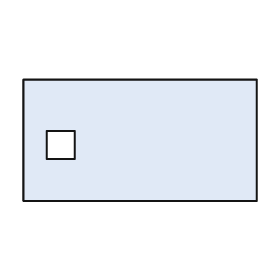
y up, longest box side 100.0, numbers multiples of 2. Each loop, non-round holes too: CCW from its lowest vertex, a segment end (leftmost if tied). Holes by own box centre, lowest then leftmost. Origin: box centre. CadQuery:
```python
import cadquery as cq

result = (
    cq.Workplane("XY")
    .moveTo(-50.0, -26.0)
    .lineTo(50.0, -26.0)
    .lineTo(50.0, 26.0)
    .lineTo(-50.0, 26.0)
    .close()
    .moveTo(-40.0, -8.0)
    .lineTo(-28.0, -8.0)
    .lineTo(-28.0, 4.0)
    .lineTo(-40.0, 4.0)
    .close()
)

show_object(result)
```